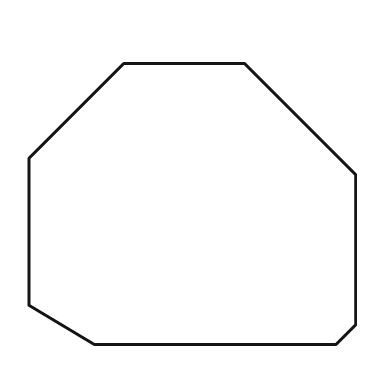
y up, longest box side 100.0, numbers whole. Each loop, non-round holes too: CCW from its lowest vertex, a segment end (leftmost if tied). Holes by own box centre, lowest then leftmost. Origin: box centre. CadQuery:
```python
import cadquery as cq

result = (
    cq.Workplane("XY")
    .moveTo(-30.0, -43.0)
    .lineTo(44.0, -43.0)
    .lineTo(50.0, -37.0)
    .lineTo(50.0, 9.0)
    .lineTo(16.0, 43.0)
    .lineTo(-21.0, 43.0)
    .lineTo(-50.0, 14.0)
    .lineTo(-50.0, -31.0)
    .close()
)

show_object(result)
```